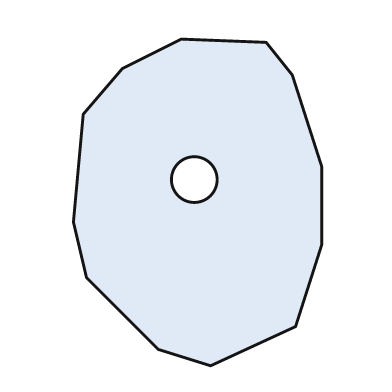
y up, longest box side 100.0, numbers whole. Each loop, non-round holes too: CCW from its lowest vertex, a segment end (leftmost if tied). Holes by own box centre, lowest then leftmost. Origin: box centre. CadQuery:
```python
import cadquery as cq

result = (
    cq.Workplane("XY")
    .moveTo(4.0, -50.0)
    .lineTo(30.0, -38.0)
    .lineTo(38.0, -13.0)
    .lineTo(38.0, 11.0)
    .lineTo(29.0, 39.0)
    .lineTo(21.0, 49.0)
    .lineTo(-5.0, 50.0)
    .lineTo(-23.0, 41.0)
    .lineTo(-35.0, 27.0)
    .lineTo(-38.0, -6.0)
    .lineTo(-34.0, -23.0)
    .lineTo(-12.0, -45.0)
    .close()
    .moveTo(-1.0, 7.0)
    .circle(7.0)
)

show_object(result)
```